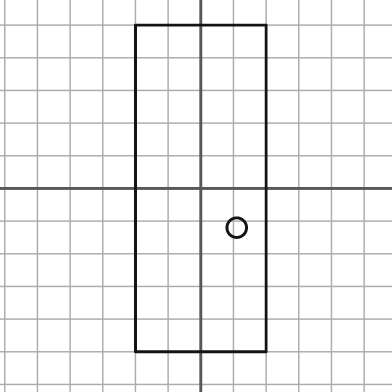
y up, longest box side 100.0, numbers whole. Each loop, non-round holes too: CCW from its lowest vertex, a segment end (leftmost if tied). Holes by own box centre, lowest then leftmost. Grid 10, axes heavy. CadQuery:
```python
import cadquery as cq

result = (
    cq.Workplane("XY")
    .moveTo(-20.0, -50.0)
    .lineTo(20.0, -50.0)
    .lineTo(20.0, 50.0)
    .lineTo(-20.0, 50.0)
    .close()
    .moveTo(11.0, -12.0)
    .circle(3.0)
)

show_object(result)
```